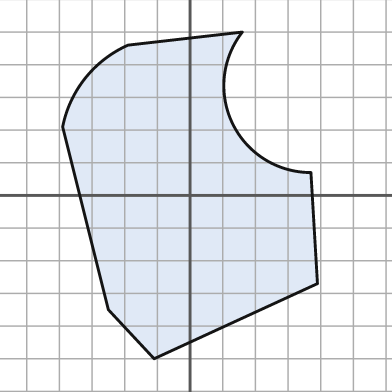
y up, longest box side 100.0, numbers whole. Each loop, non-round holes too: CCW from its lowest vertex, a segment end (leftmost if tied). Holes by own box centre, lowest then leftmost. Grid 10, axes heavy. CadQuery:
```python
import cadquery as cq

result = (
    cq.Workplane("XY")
    .moveTo(-11.0, -50.0)
    .lineTo(39.0, -27.0)
    .lineTo(37.0, 7.0)
    .threePointArc((13.0, 22.0), (16.0, 50.0))
    .lineTo(-19.0, 46.0)
    .threePointArc((-32.0, 36.0), (-39.0, 21.0))
    .lineTo(-25.0, -35.0)
    .close()
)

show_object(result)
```